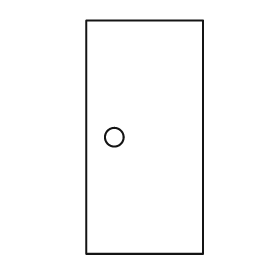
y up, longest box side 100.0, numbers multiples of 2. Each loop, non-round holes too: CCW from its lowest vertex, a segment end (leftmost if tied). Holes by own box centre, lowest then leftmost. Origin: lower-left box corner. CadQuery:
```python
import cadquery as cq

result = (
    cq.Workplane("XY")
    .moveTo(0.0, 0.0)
    .lineTo(50.0, 0.0)
    .lineTo(50.0, 100.0)
    .lineTo(0.0, 100.0)
    .close()
    .moveTo(12.0, 50.0)
    .circle(4.0)
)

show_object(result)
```